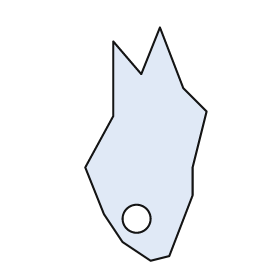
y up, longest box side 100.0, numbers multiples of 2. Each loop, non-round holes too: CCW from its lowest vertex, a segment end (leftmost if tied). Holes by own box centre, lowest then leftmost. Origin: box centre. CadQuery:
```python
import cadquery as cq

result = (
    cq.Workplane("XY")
    .moveTo(2.0, -50.0)
    .lineTo(10.0, -48.0)
    .lineTo(20.0, -22.0)
    .lineTo(20.0, -10.0)
    .lineTo(26.0, 14.0)
    .lineTo(16.0, 24.0)
    .lineTo(6.0, 50.0)
    .lineTo(-2.0, 30.0)
    .lineTo(-14.0, 44.0)
    .lineTo(-14.0, 12.0)
    .lineTo(-26.0, -10.0)
    .lineTo(-18.0, -30.0)
    .lineTo(-10.0, -42.0)
    .close()
    .moveTo(-4.0, -32.0)
    .circle(6.0)
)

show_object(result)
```